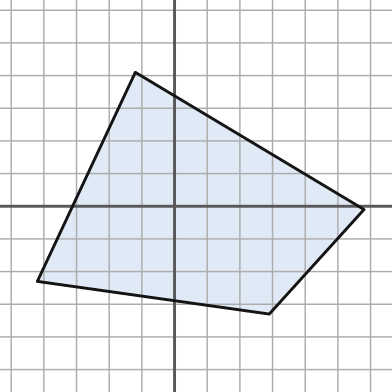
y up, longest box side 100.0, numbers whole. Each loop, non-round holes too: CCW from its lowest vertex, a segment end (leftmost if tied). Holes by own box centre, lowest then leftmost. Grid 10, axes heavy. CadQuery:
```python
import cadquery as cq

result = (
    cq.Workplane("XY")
    .moveTo(29.0, -33.0)
    .lineTo(58.0, -1.0)
    .lineTo(-12.0, 41.0)
    .lineTo(-42.0, -23.0)
    .close()
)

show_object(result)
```